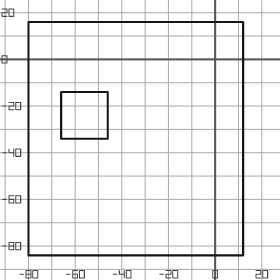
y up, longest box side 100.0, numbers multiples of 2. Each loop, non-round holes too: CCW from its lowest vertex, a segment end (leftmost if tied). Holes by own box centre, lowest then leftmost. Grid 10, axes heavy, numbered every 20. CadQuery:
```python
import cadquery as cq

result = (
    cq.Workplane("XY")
    .moveTo(-80.0, -84.0)
    .lineTo(12.0, -84.0)
    .lineTo(12.0, 16.0)
    .lineTo(-80.0, 16.0)
    .close()
    .moveTo(-66.0, -34.0)
    .lineTo(-46.0, -34.0)
    .lineTo(-46.0, -14.0)
    .lineTo(-66.0, -14.0)
    .close()
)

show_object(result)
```